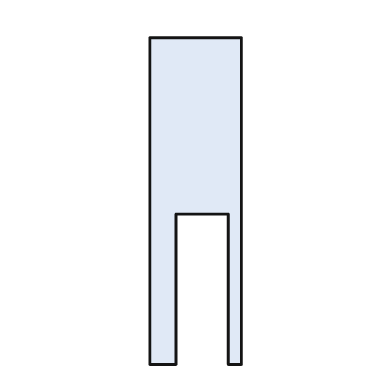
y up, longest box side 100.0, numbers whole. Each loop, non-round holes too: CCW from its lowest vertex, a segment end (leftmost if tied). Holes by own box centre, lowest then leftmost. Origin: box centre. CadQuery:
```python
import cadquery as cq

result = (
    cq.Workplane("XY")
    .moveTo(-14.0, -50.0)
    .lineTo(-6.0, -50.0)
    .lineTo(-6.0, -4.0)
    .lineTo(10.0, -4.0)
    .lineTo(10.0, -50.0)
    .lineTo(14.0, -50.0)
    .lineTo(14.0, 50.0)
    .lineTo(-14.0, 50.0)
    .close()
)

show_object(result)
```